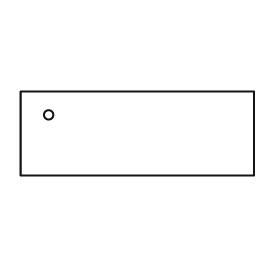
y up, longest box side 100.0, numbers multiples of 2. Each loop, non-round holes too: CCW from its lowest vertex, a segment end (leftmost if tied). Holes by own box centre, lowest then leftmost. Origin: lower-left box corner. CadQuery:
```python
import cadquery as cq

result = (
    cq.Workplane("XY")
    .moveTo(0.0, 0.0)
    .lineTo(100.0, 0.0)
    .lineTo(100.0, 36.0)
    .lineTo(0.0, 36.0)
    .close()
    .moveTo(12.0, 26.0)
    .circle(2.0)
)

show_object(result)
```